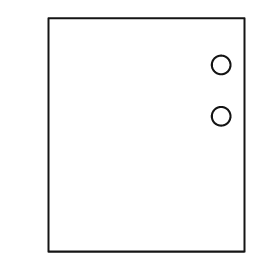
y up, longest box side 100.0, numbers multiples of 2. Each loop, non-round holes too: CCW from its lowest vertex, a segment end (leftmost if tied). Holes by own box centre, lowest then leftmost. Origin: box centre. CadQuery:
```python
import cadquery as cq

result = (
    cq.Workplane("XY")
    .moveTo(-42.0, -50.0)
    .lineTo(42.0, -50.0)
    .lineTo(42.0, 50.0)
    .lineTo(-42.0, 50.0)
    .close()
    .moveTo(32.0, 8.0)
    .circle(4.0)
    .moveTo(32.0, 30.0)
    .circle(4.0)
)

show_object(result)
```